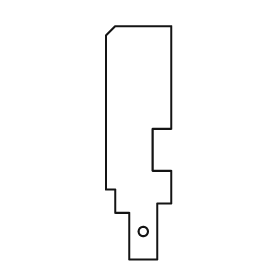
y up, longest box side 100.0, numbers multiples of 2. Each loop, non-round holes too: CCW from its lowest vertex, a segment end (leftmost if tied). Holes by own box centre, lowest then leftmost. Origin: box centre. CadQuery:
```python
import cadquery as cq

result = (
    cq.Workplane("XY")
    .moveTo(-4.0, -50.0)
    .lineTo(8.0, -50.0)
    .lineTo(8.0, -26.0)
    .lineTo(14.0, -26.0)
    .lineTo(14.0, -12.0)
    .lineTo(6.0, -12.0)
    .lineTo(6.0, 6.0)
    .lineTo(14.0, 6.0)
    .lineTo(14.0, 50.0)
    .lineTo(-10.0, 50.0)
    .lineTo(-14.0, 46.0)
    .lineTo(-14.0, -20.0)
    .lineTo(-10.0, -20.0)
    .lineTo(-10.0, -30.0)
    .lineTo(-4.0, -30.0)
    .close()
    .moveTo(2.0, -38.0)
    .circle(2.0)
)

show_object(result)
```